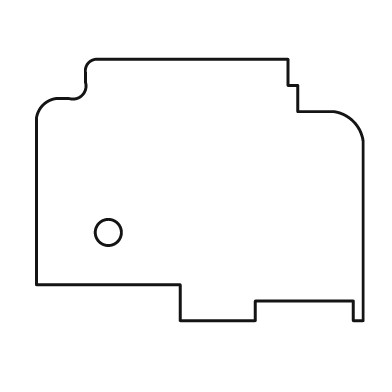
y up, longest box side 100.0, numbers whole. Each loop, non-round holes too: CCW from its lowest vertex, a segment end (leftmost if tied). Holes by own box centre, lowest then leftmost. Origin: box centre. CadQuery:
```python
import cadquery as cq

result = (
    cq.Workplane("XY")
    .moveTo(-6.0, -40.0)
    .lineTo(17.0, -40.0)
    .lineTo(17.0, -34.0)
    .lineTo(47.0, -34.0)
    .lineTo(47.0, -40.0)
    .lineTo(50.0, -40.0)
    .lineTo(50.0, 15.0)
    .threePointArc((47.0, 21.0), (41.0, 24.0))
    .lineTo(30.0, 24.0)
    .lineTo(30.0, 32.0)
    .lineTo(27.0, 32.0)
    .lineTo(27.0, 40.0)
    .lineTo(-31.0, 40.0)
    .threePointArc((-34.0, 39.0), (-35.0, 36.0))
    .lineTo(-35.0, 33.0)
    .threePointArc((-36.0, 29.0), (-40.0, 28.0))
    .lineTo(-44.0, 28.0)
    .threePointArc((-48.0, 26.0), (-50.0, 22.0))
    .lineTo(-50.0, -29.0)
    .lineTo(-6.0, -29.0)
    .close()
    .moveTo(-28.0, -13.0)
    .circle(4.0)
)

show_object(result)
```